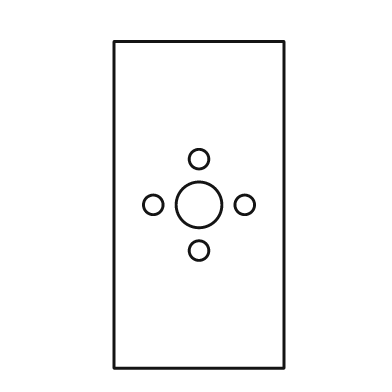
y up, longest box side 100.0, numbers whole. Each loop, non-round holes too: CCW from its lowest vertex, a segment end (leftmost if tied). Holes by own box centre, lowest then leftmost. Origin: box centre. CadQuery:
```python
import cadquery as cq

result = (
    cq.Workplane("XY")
    .moveTo(-26.0, -50.0)
    .lineTo(26.0, -50.0)
    .lineTo(26.0, 50.0)
    .lineTo(-26.0, 50.0)
    .close()
    .moveTo(0.0, -14.0)
    .circle(3.0)
    .moveTo(-14.0, 0.0)
    .circle(3.0)
    .moveTo(0.0, 0.0)
    .circle(7.0)
    .moveTo(14.0, 0.0)
    .circle(3.0)
    .moveTo(0.0, 14.0)
    .circle(3.0)
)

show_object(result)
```